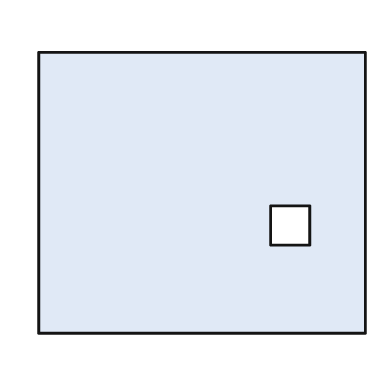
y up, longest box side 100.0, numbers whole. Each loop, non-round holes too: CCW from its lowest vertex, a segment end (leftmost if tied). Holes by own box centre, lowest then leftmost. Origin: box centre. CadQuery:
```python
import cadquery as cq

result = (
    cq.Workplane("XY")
    .moveTo(-50.0, -43.0)
    .lineTo(50.0, -43.0)
    .lineTo(50.0, 43.0)
    .lineTo(-50.0, 43.0)
    .close()
    .moveTo(21.0, -16.0)
    .lineTo(33.0, -16.0)
    .lineTo(33.0, -4.0)
    .lineTo(21.0, -4.0)
    .close()
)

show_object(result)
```